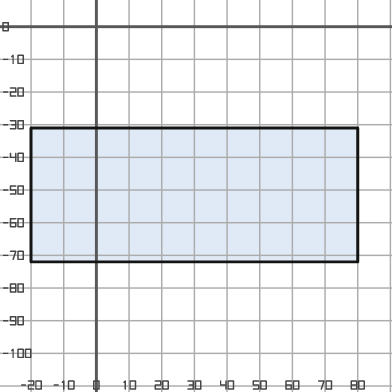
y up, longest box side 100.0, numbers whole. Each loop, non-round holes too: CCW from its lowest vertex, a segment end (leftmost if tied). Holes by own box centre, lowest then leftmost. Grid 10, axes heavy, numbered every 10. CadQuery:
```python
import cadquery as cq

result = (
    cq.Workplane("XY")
    .moveTo(-20.0, -72.0)
    .lineTo(80.0, -72.0)
    .lineTo(80.0, -31.0)
    .lineTo(-20.0, -31.0)
    .close()
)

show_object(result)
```